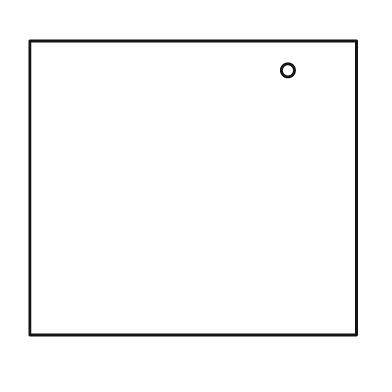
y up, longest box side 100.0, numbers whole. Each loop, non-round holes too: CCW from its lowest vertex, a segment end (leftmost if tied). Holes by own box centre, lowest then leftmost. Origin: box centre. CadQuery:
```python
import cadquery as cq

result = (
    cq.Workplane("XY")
    .moveTo(-50.0, -45.0)
    .lineTo(50.0, -45.0)
    .lineTo(50.0, 45.0)
    .lineTo(-50.0, 45.0)
    .close()
    .moveTo(29.0, 36.0)
    .circle(2.0)
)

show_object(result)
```